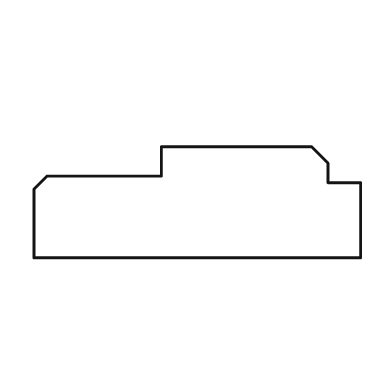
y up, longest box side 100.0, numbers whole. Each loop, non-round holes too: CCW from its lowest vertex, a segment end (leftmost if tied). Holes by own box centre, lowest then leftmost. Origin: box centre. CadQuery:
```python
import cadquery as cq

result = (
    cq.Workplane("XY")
    .moveTo(-50.0, -17.0)
    .lineTo(50.0, -17.0)
    .lineTo(50.0, 6.0)
    .lineTo(40.0, 6.0)
    .lineTo(40.0, 12.0)
    .lineTo(35.0, 17.0)
    .lineTo(-11.0, 17.0)
    .lineTo(-11.0, 8.0)
    .lineTo(-46.0, 8.0)
    .lineTo(-50.0, 4.0)
    .close()
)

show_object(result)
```